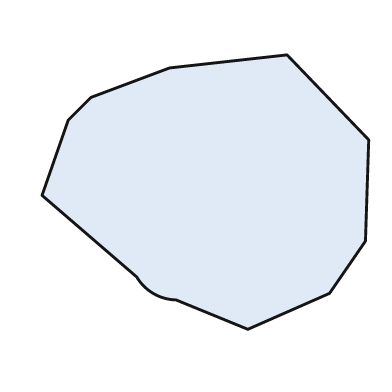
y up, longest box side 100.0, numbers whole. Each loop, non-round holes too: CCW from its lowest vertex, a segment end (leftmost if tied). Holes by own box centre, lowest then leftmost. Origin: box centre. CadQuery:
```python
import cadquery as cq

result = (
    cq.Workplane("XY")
    .moveTo(13.0, -42.0)
    .lineTo(38.0, -31.0)
    .lineTo(49.0, -15.0)
    .lineTo(50.0, 16.0)
    .lineTo(25.0, 42.0)
    .lineTo(-11.0, 38.0)
    .lineTo(-35.0, 29.0)
    .lineTo(-42.0, 22.0)
    .lineTo(-50.0, -1.0)
    .lineTo(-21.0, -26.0)
    .threePointArc((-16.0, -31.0), (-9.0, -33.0))
    .close()
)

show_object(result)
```